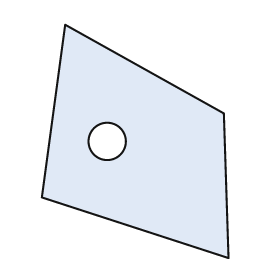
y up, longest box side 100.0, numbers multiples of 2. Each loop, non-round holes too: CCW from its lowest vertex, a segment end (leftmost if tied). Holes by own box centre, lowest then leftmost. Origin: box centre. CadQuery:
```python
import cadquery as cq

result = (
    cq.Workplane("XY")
    .moveTo(40.0, -50.0)
    .lineTo(38.0, 12.0)
    .lineTo(-30.0, 50.0)
    .lineTo(-40.0, -24.0)
    .close()
    .moveTo(-12.0, 0.0)
    .circle(8.0)
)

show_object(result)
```